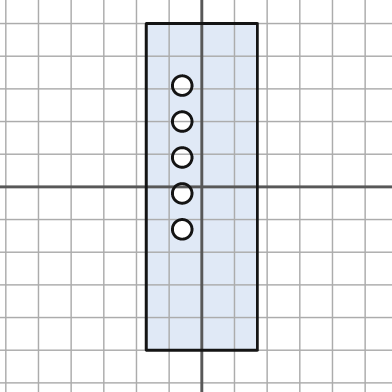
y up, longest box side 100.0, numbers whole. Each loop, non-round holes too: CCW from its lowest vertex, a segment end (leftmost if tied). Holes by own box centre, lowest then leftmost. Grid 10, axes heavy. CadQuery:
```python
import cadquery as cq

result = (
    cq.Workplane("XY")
    .moveTo(-17.0, -50.0)
    .lineTo(17.0, -50.0)
    .lineTo(17.0, 50.0)
    .lineTo(-17.0, 50.0)
    .close()
    .moveTo(-6.0, -13.0)
    .circle(3.0)
    .moveTo(-6.0, -2.0)
    .circle(3.0)
    .moveTo(-6.0, 9.0)
    .circle(3.0)
    .moveTo(-6.0, 20.0)
    .circle(3.0)
    .moveTo(-6.0, 31.0)
    .circle(3.0)
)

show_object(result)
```